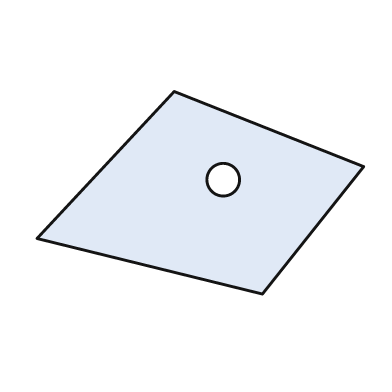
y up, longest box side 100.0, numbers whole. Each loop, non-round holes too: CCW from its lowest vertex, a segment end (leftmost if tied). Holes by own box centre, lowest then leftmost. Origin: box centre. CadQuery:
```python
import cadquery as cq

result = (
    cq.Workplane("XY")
    .moveTo(19.0, -31.0)
    .lineTo(50.0, 8.0)
    .lineTo(-8.0, 31.0)
    .lineTo(-50.0, -14.0)
    .close()
    .moveTo(7.0, 4.0)
    .circle(5.0)
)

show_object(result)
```